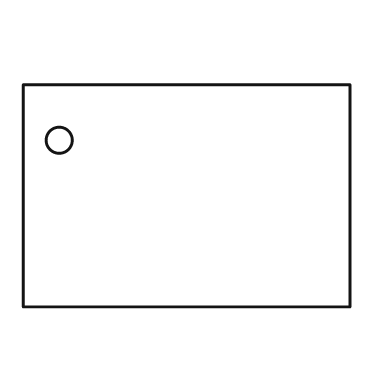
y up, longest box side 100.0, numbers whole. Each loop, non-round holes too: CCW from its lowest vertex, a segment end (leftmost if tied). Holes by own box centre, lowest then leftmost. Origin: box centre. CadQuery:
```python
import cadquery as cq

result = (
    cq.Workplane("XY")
    .moveTo(-50.0, -34.0)
    .lineTo(50.0, -34.0)
    .lineTo(50.0, 34.0)
    .lineTo(-50.0, 34.0)
    .close()
    .moveTo(-39.0, 17.0)
    .circle(4.0)
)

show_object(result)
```